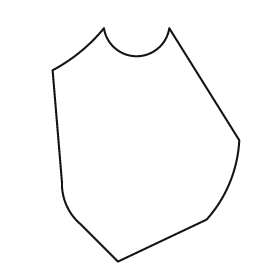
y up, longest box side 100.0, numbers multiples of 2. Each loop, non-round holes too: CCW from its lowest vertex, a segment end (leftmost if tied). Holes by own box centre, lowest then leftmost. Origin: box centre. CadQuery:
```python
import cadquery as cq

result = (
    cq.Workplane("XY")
    .moveTo(-12.0, -50.0)
    .lineTo(26.0, -32.0)
    .threePointArc((36.0, -16.0), (40.0, 2.0))
    .lineTo(10.0, 50.0)
    .threePointArc((-4.0, 38.0), (-18.0, 50.0))
    .threePointArc((-28.0, 40.0), (-40.0, 32.0))
    .lineTo(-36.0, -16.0)
    .threePointArc((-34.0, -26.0), (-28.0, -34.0))
    .close()
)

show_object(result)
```